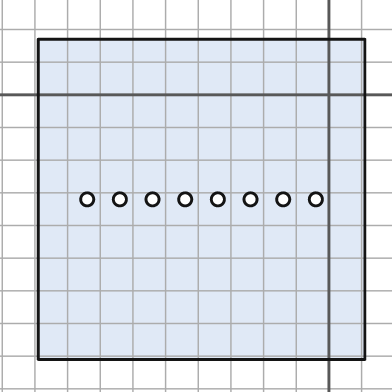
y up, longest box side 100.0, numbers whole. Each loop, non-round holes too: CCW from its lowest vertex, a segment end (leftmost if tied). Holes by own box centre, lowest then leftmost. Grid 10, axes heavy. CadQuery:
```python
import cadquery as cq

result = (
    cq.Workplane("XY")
    .moveTo(-89.0, -81.0)
    .lineTo(11.0, -81.0)
    .lineTo(11.0, 17.0)
    .lineTo(-89.0, 17.0)
    .close()
    .moveTo(-74.0, -32.0)
    .circle(2.0)
    .moveTo(-64.0, -32.0)
    .circle(2.0)
    .moveTo(-54.0, -32.0)
    .circle(2.0)
    .moveTo(-44.0, -32.0)
    .circle(2.0)
    .moveTo(-34.0, -32.0)
    .circle(2.0)
    .moveTo(-24.0, -32.0)
    .circle(2.0)
    .moveTo(-14.0, -32.0)
    .circle(2.0)
    .moveTo(-4.0, -32.0)
    .circle(2.0)
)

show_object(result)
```